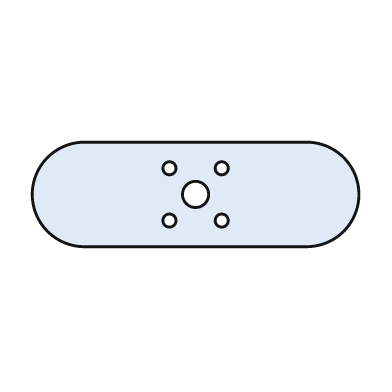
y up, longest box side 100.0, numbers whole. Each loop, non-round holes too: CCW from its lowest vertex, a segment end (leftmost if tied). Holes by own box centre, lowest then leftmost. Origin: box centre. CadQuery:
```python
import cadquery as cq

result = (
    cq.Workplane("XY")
    .moveTo(-34.0, -16.0)
    .lineTo(34.0, -16.0)
    .threePointArc((50.0, 0.0), (34.0, 16.0))
    .lineTo(-34.0, 16.0)
    .threePointArc((-50.0, 0.0), (-34.0, -16.0))
    .close()
    .moveTo(-8.0, -8.0)
    .circle(2.0)
    .moveTo(8.0, -8.0)
    .circle(2.0)
    .moveTo(0.0, 0.0)
    .circle(4.0)
    .moveTo(-8.0, 8.0)
    .circle(2.0)
    .moveTo(8.0, 8.0)
    .circle(2.0)
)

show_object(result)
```